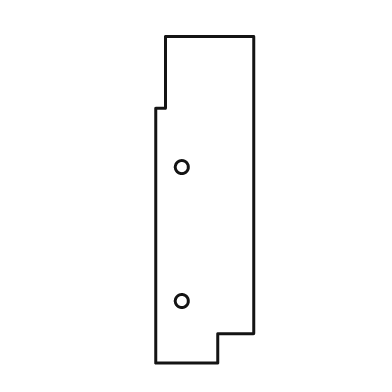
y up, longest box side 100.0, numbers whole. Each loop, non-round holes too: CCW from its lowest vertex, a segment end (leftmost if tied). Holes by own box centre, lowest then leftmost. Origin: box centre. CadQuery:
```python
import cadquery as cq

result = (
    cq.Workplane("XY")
    .moveTo(-15.0, -50.0)
    .lineTo(4.0, -50.0)
    .lineTo(4.0, -41.0)
    .lineTo(15.0, -41.0)
    .lineTo(15.0, 50.0)
    .lineTo(-12.0, 50.0)
    .lineTo(-12.0, 28.0)
    .lineTo(-15.0, 28.0)
    .close()
    .moveTo(-7.0, -31.0)
    .circle(2.0)
    .moveTo(-7.0, 10.0)
    .circle(2.0)
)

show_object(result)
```